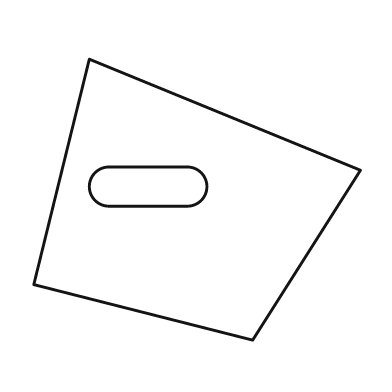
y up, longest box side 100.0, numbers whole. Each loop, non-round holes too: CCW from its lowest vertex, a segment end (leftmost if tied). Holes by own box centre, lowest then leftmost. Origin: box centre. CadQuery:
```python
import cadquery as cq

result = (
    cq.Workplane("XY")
    .moveTo(17.0, -43.0)
    .lineTo(50.0, 9.0)
    .lineTo(-33.0, 43.0)
    .lineTo(-50.0, -26.0)
    .close()
    .moveTo(-27.0, -2.0)
    .lineTo(-3.0, -2.0)
    .threePointArc((3.0, 4.0), (-3.0, 10.0))
    .lineTo(-27.0, 10.0)
    .threePointArc((-33.0, 4.0), (-27.0, -2.0))
    .close()
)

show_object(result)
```